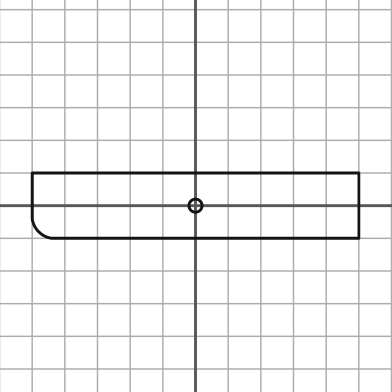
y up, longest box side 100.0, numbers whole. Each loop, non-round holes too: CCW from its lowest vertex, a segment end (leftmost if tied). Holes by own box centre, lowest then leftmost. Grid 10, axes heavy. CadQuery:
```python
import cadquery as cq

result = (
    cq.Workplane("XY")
    .moveTo(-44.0, -10.0)
    .lineTo(50.0, -10.0)
    .lineTo(50.0, 10.0)
    .lineTo(-50.0, 10.0)
    .lineTo(-50.0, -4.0)
    .threePointArc((-48.0, -8.0), (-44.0, -10.0))
    .close()
    .moveTo(0.0, 0.0)
    .circle(2.0)
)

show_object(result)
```